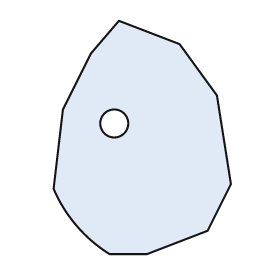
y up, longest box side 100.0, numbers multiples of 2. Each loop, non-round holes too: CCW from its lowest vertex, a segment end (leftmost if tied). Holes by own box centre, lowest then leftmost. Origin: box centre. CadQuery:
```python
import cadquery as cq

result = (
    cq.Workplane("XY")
    .moveTo(-14.0, -50.0)
    .lineTo(2.0, -50.0)
    .lineTo(28.0, -40.0)
    .lineTo(38.0, -20.0)
    .lineTo(32.0, 18.0)
    .lineTo(16.0, 40.0)
    .lineTo(-10.0, 50.0)
    .lineTo(-22.0, 36.0)
    .lineTo(-34.0, 12.0)
    .lineTo(-38.0, -22.0)
    .threePointArc((-28.0, -38.0), (-14.0, -50.0))
    .close()
    .moveTo(-12.0, 6.0)
    .circle(6.0)
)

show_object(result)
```